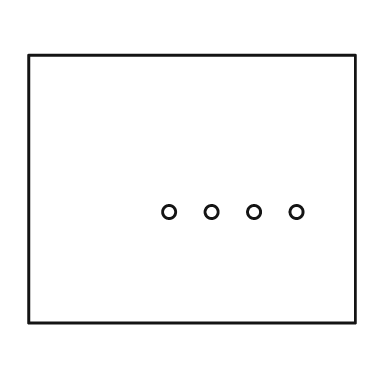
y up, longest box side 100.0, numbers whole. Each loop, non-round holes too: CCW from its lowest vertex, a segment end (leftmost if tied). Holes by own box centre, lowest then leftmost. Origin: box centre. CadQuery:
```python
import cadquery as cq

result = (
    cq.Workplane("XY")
    .moveTo(-50.0, -41.0)
    .lineTo(50.0, -41.0)
    .lineTo(50.0, 41.0)
    .lineTo(-50.0, 41.0)
    .close()
    .moveTo(-7.0, -7.0)
    .circle(2.0)
    .moveTo(6.0, -7.0)
    .circle(2.0)
    .moveTo(19.0, -7.0)
    .circle(2.0)
    .moveTo(32.0, -7.0)
    .circle(2.0)
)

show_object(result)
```